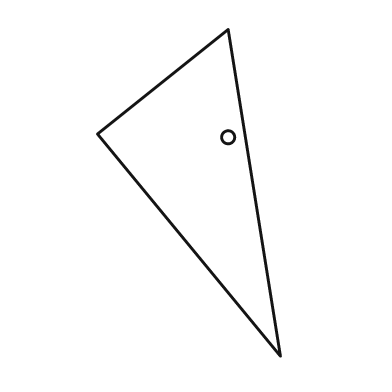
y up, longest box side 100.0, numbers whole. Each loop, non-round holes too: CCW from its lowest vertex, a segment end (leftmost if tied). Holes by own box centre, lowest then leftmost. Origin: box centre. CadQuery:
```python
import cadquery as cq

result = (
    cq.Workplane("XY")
    .moveTo(28.0, -50.0)
    .lineTo(12.0, 50.0)
    .lineTo(-28.0, 18.0)
    .close()
    .moveTo(12.0, 17.0)
    .circle(2.0)
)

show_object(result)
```